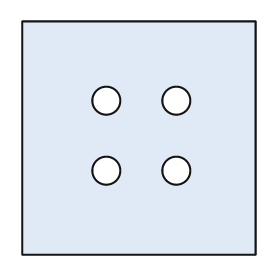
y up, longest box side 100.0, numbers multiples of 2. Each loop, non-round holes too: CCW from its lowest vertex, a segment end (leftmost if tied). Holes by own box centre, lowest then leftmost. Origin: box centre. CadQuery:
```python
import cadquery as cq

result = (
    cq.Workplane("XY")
    .moveTo(-50.0, -50.0)
    .lineTo(50.0, -50.0)
    .lineTo(50.0, 50.0)
    .lineTo(-50.0, 50.0)
    .close()
    .moveTo(-14.0, -14.0)
    .circle(6.0)
    .moveTo(16.0, -14.0)
    .circle(6.0)
    .moveTo(-14.0, 16.0)
    .circle(6.0)
    .moveTo(16.0, 16.0)
    .circle(6.0)
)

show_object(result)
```